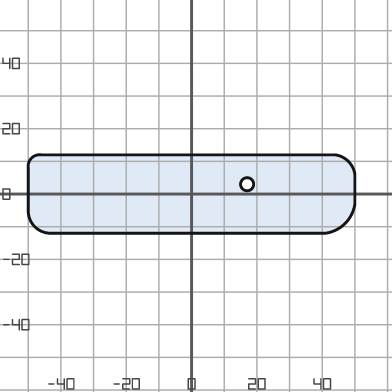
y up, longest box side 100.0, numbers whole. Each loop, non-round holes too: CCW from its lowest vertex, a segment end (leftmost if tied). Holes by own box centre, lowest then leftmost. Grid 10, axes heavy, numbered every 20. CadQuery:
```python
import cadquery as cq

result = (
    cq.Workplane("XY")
    .moveTo(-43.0, -12.0)
    .lineTo(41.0, -12.0)
    .threePointArc((47.0, -9.0), (50.0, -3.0))
    .lineTo(50.0, 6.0)
    .threePointArc((48.0, 10.0), (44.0, 12.0))
    .lineTo(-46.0, 12.0)
    .threePointArc((-49.0, 11.0), (-50.0, 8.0))
    .lineTo(-50.0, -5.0)
    .threePointArc((-48.0, -10.0), (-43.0, -12.0))
    .close()
    .moveTo(17.0, 3.0)
    .circle(2.0)
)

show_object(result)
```